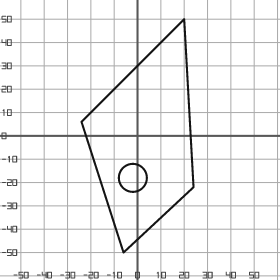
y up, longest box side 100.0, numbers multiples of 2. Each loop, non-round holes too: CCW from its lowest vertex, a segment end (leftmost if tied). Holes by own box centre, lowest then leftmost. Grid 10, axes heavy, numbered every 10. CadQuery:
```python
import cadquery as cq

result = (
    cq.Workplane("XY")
    .moveTo(-6.0, -50.0)
    .lineTo(24.0, -22.0)
    .lineTo(20.0, 50.0)
    .lineTo(-24.0, 6.0)
    .close()
    .moveTo(-2.0, -18.0)
    .circle(6.0)
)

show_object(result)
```